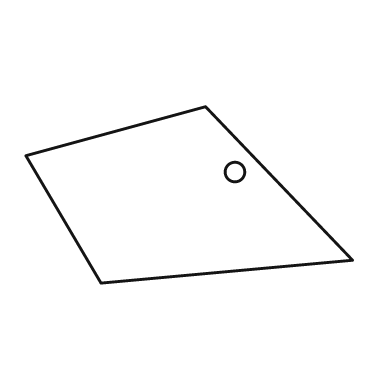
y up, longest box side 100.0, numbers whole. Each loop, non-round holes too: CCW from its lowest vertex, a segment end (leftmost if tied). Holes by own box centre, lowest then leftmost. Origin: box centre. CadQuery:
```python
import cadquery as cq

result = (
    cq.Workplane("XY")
    .moveTo(-27.0, -27.0)
    .lineTo(50.0, -20.0)
    .lineTo(5.0, 27.0)
    .lineTo(-50.0, 12.0)
    .close()
    .moveTo(14.0, 7.0)
    .circle(3.0)
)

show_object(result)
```